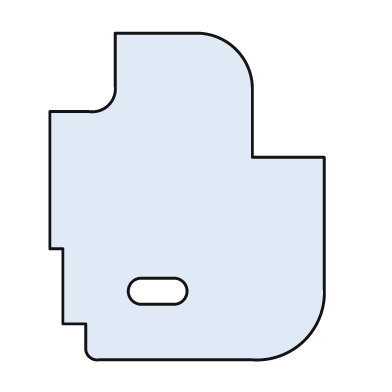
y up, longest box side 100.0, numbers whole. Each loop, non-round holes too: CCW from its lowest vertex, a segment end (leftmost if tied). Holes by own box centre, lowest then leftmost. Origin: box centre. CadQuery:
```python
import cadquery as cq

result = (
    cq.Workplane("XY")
    .moveTo(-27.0, -50.0)
    .lineTo(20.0, -50.0)
    .threePointArc((36.0, -44.0), (42.0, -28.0))
    .lineTo(42.0, 12.0)
    .lineTo(20.0, 12.0)
    .lineTo(20.0, 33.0)
    .threePointArc((15.0, 45.0), (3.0, 50.0))
    .lineTo(-22.0, 50.0)
    .lineTo(-22.0, 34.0)
    .threePointArc((-24.0, 28.0), (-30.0, 26.0))
    .lineTo(-42.0, 26.0)
    .lineTo(-42.0, -16.0)
    .lineTo(-38.0, -16.0)
    .lineTo(-38.0, -39.0)
    .lineTo(-31.0, -39.0)
    .lineTo(-31.0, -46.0)
    .threePointArc((-30.0, -49.0), (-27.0, -50.0))
    .close()
    .moveTo(-14.0, -33.0)
    .lineTo(-4.0, -33.0)
    .threePointArc((0.0, -29.0), (-4.0, -25.0))
    .lineTo(-14.0, -25.0)
    .threePointArc((-18.0, -29.0), (-14.0, -33.0))
    .close()
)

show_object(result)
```